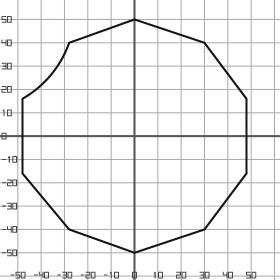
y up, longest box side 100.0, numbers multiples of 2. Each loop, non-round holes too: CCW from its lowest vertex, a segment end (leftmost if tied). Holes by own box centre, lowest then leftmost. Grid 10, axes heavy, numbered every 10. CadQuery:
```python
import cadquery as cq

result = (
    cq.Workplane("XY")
    .moveTo(0.0, -50.0)
    .lineTo(30.0, -40.0)
    .lineTo(48.0, -16.0)
    .lineTo(48.0, 16.0)
    .lineTo(30.0, 40.0)
    .lineTo(0.0, 50.0)
    .lineTo(-28.0, 40.0)
    .threePointArc((-36.0, 26.0), (-48.0, 16.0))
    .lineTo(-48.0, -16.0)
    .lineTo(-28.0, -40.0)
    .close()
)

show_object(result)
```